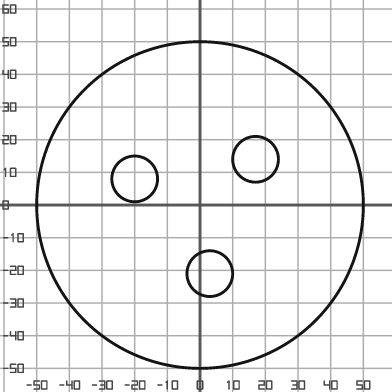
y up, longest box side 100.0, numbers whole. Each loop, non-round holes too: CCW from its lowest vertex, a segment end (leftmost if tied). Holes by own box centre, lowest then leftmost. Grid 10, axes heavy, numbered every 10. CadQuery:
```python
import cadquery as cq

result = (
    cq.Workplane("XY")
    .moveTo(0.0, 0.0)
    .circle(50.0)
    .moveTo(3.0, -21.0)
    .circle(7.0)
    .moveTo(-20.0, 8.0)
    .circle(7.0)
    .moveTo(17.0, 14.0)
    .circle(7.0)
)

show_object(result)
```